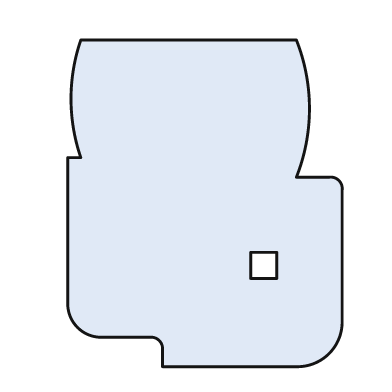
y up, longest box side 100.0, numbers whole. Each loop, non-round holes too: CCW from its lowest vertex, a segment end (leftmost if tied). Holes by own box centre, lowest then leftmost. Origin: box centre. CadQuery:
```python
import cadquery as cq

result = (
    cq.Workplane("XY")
    .moveTo(-13.0, -50.0)
    .lineTo(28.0, -50.0)
    .threePointArc((38.0, -46.0), (42.0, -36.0))
    .lineTo(42.0, 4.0)
    .threePointArc((41.0, 7.0), (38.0, 8.0))
    .lineTo(28.0, 8.0)
    .threePointArc((32.0, 29.0), (28.0, 50.0))
    .lineTo(-38.0, 50.0)
    .threePointArc((-41.0, 32.0), (-38.0, 14.0))
    .lineTo(-42.0, 14.0)
    .lineTo(-42.0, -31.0)
    .threePointArc((-39.0, -38.0), (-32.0, -41.0))
    .lineTo(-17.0, -41.0)
    .threePointArc((-14.0, -42.0), (-13.0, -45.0))
    .close()
    .moveTo(14.0, -23.0)
    .lineTo(22.0, -23.0)
    .lineTo(22.0, -15.0)
    .lineTo(14.0, -15.0)
    .close()
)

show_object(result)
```